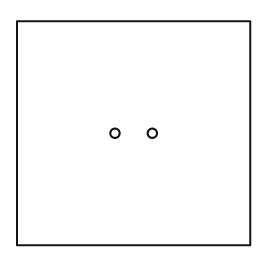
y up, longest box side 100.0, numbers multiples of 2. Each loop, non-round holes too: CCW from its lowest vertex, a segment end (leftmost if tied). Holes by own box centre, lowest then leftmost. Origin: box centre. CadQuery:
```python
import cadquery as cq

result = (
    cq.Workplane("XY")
    .moveTo(-50.0, -48.0)
    .lineTo(50.0, -48.0)
    .lineTo(50.0, 48.0)
    .lineTo(-50.0, 48.0)
    .close()
    .moveTo(-8.0, 0.0)
    .circle(2.0)
    .moveTo(8.0, 0.0)
    .circle(2.0)
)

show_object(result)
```